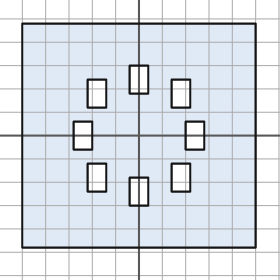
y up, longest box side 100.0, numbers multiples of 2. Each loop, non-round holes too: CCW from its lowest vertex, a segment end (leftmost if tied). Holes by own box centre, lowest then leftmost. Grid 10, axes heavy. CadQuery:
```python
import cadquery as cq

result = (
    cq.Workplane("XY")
    .moveTo(-50.0, -48.0)
    .lineTo(50.0, -48.0)
    .lineTo(50.0, 48.0)
    .lineTo(-50.0, 48.0)
    .close()
    .moveTo(-4.0, -30.0)
    .lineTo(4.0, -30.0)
    .lineTo(4.0, -18.0)
    .lineTo(-4.0, -18.0)
    .close()
    .moveTo(-22.0, -24.0)
    .lineTo(-14.0, -24.0)
    .lineTo(-14.0, -12.0)
    .lineTo(-22.0, -12.0)
    .close()
    .moveTo(14.0, -24.0)
    .lineTo(22.0, -24.0)
    .lineTo(22.0, -12.0)
    .lineTo(14.0, -12.0)
    .close()
    .moveTo(-28.0, -6.0)
    .lineTo(-20.0, -6.0)
    .lineTo(-20.0, 6.0)
    .lineTo(-28.0, 6.0)
    .close()
    .moveTo(20.0, -6.0)
    .lineTo(28.0, -6.0)
    .lineTo(28.0, 6.0)
    .lineTo(20.0, 6.0)
    .close()
    .moveTo(-22.0, 12.0)
    .lineTo(-14.0, 12.0)
    .lineTo(-14.0, 24.0)
    .lineTo(-22.0, 24.0)
    .close()
    .moveTo(14.0, 12.0)
    .lineTo(22.0, 12.0)
    .lineTo(22.0, 24.0)
    .lineTo(14.0, 24.0)
    .close()
    .moveTo(-4.0, 18.0)
    .lineTo(4.0, 18.0)
    .lineTo(4.0, 30.0)
    .lineTo(-4.0, 30.0)
    .close()
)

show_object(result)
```